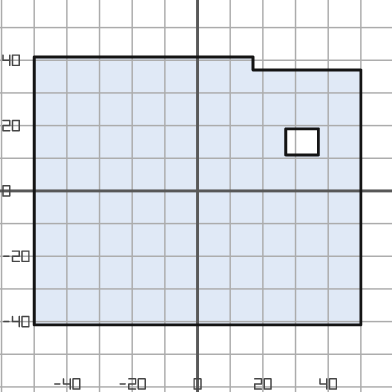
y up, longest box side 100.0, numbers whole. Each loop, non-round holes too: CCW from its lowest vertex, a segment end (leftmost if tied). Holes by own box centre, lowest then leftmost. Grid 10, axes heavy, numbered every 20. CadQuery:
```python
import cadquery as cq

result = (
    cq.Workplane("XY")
    .moveTo(-50.0, -41.0)
    .lineTo(50.0, -41.0)
    .lineTo(50.0, 37.0)
    .lineTo(17.0, 37.0)
    .lineTo(17.0, 41.0)
    .lineTo(-50.0, 41.0)
    .close()
    .moveTo(27.0, 11.0)
    .lineTo(37.0, 11.0)
    .lineTo(37.0, 19.0)
    .lineTo(27.0, 19.0)
    .close()
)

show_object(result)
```